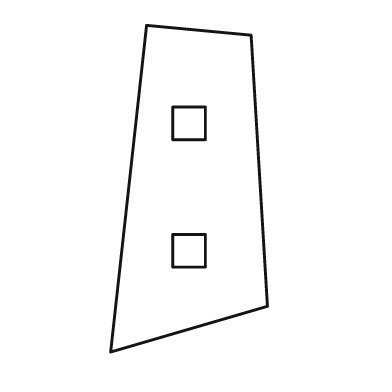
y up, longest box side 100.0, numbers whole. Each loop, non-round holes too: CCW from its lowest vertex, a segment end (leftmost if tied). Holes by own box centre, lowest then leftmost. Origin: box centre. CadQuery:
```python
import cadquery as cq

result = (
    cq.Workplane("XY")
    .moveTo(-24.0, -50.0)
    .lineTo(24.0, -36.0)
    .lineTo(19.0, 47.0)
    .lineTo(-13.0, 50.0)
    .close()
    .moveTo(-5.0, -24.0)
    .lineTo(5.0, -24.0)
    .lineTo(5.0, -14.0)
    .lineTo(-5.0, -14.0)
    .close()
    .moveTo(-5.0, 15.0)
    .lineTo(5.0, 15.0)
    .lineTo(5.0, 25.0)
    .lineTo(-5.0, 25.0)
    .close()
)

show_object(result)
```